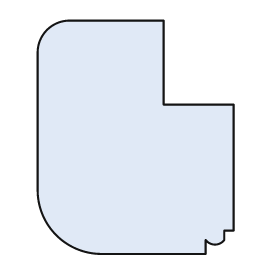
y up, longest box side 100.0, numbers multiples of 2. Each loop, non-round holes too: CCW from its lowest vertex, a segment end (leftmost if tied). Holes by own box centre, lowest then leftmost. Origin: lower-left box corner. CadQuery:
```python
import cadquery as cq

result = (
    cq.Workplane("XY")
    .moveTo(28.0, 0.0)
    .lineTo(72.0, 0.0)
    .lineTo(72.0, 6.0)
    .threePointArc((76.0, 4.0), (80.0, 6.0))
    .lineTo(80.0, 10.0)
    .lineTo(84.0, 10.0)
    .lineTo(84.0, 64.0)
    .lineTo(54.0, 64.0)
    .lineTo(54.0, 100.0)
    .lineTo(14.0, 100.0)
    .threePointArc((4.0, 96.0), (0.0, 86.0))
    .lineTo(0.0, 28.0)
    .threePointArc((8.0, 8.0), (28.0, 0.0))
    .close()
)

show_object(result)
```